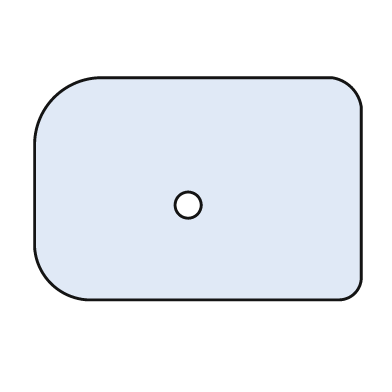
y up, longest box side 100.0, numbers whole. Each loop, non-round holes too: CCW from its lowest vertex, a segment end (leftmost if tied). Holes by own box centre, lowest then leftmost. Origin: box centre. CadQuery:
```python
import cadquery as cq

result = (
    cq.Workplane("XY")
    .moveTo(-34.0, -34.0)
    .lineTo(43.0, -34.0)
    .threePointArc((48.0, -32.0), (50.0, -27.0))
    .lineTo(50.0, 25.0)
    .threePointArc((47.0, 31.0), (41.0, 34.0))
    .lineTo(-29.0, 34.0)
    .threePointArc((-44.0, 28.0), (-50.0, 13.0))
    .lineTo(-50.0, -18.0)
    .threePointArc((-45.0, -29.0), (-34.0, -34.0))
    .close()
    .moveTo(-3.0, -5.0)
    .circle(4.0)
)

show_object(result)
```